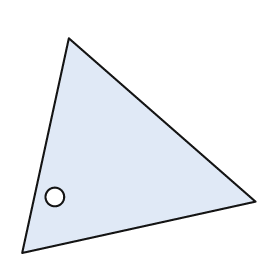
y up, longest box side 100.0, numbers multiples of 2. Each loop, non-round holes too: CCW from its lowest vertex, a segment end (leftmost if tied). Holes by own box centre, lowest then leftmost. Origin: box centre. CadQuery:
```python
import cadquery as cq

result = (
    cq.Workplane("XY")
    .moveTo(-50.0, -46.0)
    .lineTo(50.0, -24.0)
    .lineTo(-30.0, 46.0)
    .close()
    .moveTo(-36.0, -22.0)
    .circle(4.0)
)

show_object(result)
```